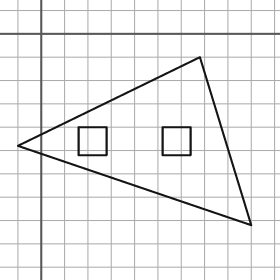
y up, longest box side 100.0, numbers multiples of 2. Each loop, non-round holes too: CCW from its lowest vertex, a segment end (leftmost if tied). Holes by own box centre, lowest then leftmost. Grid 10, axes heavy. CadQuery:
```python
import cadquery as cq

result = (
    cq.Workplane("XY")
    .moveTo(90.0, -82.0)
    .lineTo(68.0, -10.0)
    .lineTo(-10.0, -48.0)
    .close()
    .moveTo(16.0, -52.0)
    .lineTo(28.0, -52.0)
    .lineTo(28.0, -40.0)
    .lineTo(16.0, -40.0)
    .close()
    .moveTo(52.0, -52.0)
    .lineTo(64.0, -52.0)
    .lineTo(64.0, -40.0)
    .lineTo(52.0, -40.0)
    .close()
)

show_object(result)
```